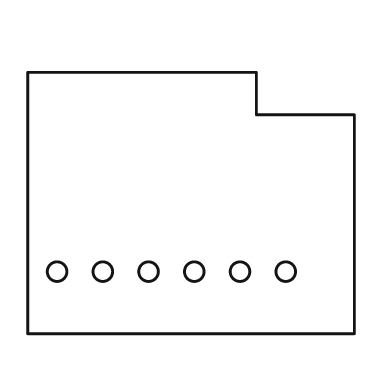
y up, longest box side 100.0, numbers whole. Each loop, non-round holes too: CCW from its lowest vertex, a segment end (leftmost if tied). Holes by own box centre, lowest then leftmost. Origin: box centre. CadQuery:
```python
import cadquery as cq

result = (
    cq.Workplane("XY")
    .moveTo(-50.0, -40.0)
    .lineTo(50.0, -40.0)
    .lineTo(50.0, 27.0)
    .lineTo(20.0, 27.0)
    .lineTo(20.0, 40.0)
    .lineTo(-50.0, 40.0)
    .close()
    .moveTo(-41.0, -21.0)
    .circle(3.0)
    .moveTo(-27.0, -21.0)
    .circle(3.0)
    .moveTo(-13.0, -21.0)
    .circle(3.0)
    .moveTo(1.0, -21.0)
    .circle(3.0)
    .moveTo(15.0, -21.0)
    .circle(3.0)
    .moveTo(29.0, -21.0)
    .circle(3.0)
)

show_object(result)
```